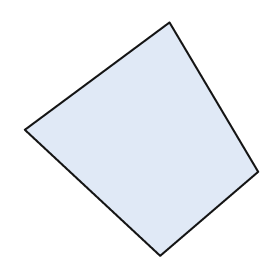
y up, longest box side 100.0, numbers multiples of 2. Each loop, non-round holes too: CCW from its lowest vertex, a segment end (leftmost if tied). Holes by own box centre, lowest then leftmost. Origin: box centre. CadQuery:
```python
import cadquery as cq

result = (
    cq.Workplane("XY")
    .moveTo(8.0, -50.0)
    .lineTo(50.0, -14.0)
    .lineTo(12.0, 50.0)
    .lineTo(-50.0, 4.0)
    .close()
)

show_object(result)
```